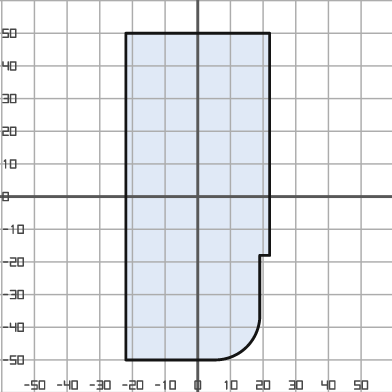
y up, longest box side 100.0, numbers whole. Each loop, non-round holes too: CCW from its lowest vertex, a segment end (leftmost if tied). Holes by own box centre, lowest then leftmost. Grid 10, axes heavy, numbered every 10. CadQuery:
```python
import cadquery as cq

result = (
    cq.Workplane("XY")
    .moveTo(-22.0, -50.0)
    .lineTo(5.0, -50.0)
    .threePointArc((15.0, -46.0), (19.0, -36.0))
    .lineTo(19.0, -18.0)
    .lineTo(22.0, -18.0)
    .lineTo(22.0, 50.0)
    .lineTo(-22.0, 50.0)
    .close()
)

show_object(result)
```